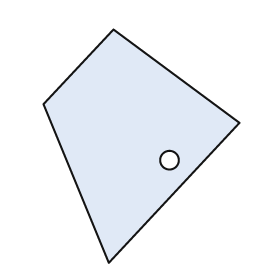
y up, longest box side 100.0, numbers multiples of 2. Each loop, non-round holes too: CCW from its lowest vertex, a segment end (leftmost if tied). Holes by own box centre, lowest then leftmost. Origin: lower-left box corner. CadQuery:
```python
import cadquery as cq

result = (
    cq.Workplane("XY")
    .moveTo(28.0, 0.0)
    .lineTo(84.0, 60.0)
    .lineTo(30.0, 100.0)
    .lineTo(0.0, 68.0)
    .close()
    .moveTo(54.0, 44.0)
    .circle(4.0)
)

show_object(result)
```